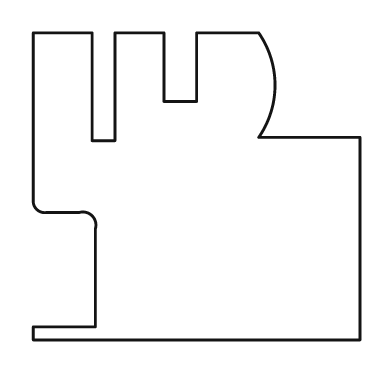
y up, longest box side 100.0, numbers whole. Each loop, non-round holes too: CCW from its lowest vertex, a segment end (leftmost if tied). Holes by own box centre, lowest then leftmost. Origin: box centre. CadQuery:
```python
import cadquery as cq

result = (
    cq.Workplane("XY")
    .moveTo(-50.0, -47.0)
    .lineTo(50.0, -47.0)
    .lineTo(50.0, 15.0)
    .lineTo(19.0, 15.0)
    .threePointArc((24.0, 31.0), (19.0, 47.0))
    .lineTo(0.0, 47.0)
    .lineTo(0.0, 26.0)
    .lineTo(-10.0, 26.0)
    .lineTo(-10.0, 47.0)
    .lineTo(-25.0, 47.0)
    .lineTo(-25.0, 14.0)
    .lineTo(-32.0, 14.0)
    .lineTo(-32.0, 47.0)
    .lineTo(-50.0, 47.0)
    .lineTo(-50.0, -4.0)
    .threePointArc((-49.0, -7.0), (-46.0, -8.0))
    .lineTo(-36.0, -8.0)
    .threePointArc((-32.0, -9.0), (-31.0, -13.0))
    .lineTo(-31.0, -43.0)
    .lineTo(-50.0, -43.0)
    .close()
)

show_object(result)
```